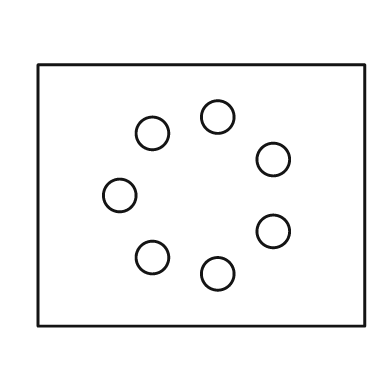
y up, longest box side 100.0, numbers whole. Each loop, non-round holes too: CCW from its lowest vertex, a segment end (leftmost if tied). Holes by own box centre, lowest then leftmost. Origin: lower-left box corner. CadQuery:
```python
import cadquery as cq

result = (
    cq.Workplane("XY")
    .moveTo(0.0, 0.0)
    .lineTo(100.0, 0.0)
    .lineTo(100.0, 80.0)
    .lineTo(0.0, 80.0)
    .close()
    .moveTo(55.0, 16.0)
    .circle(5.0)
    .moveTo(35.0, 21.0)
    .circle(5.0)
    .moveTo(72.0, 29.0)
    .circle(5.0)
    .moveTo(25.0, 40.0)
    .circle(5.0)
    .moveTo(72.0, 51.0)
    .circle(5.0)
    .moveTo(35.0, 59.0)
    .circle(5.0)
    .moveTo(55.0, 64.0)
    .circle(5.0)
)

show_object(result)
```